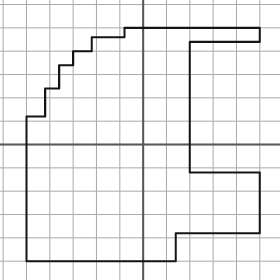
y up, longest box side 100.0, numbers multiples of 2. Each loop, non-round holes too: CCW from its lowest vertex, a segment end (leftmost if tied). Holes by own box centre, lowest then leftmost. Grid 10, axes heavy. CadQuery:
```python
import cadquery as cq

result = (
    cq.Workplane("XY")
    .moveTo(-50.0, -50.0)
    .lineTo(14.0, -50.0)
    .lineTo(14.0, -38.0)
    .lineTo(50.0, -38.0)
    .lineTo(50.0, -12.0)
    .lineTo(20.0, -12.0)
    .lineTo(20.0, 44.0)
    .lineTo(50.0, 44.0)
    .lineTo(50.0, 50.0)
    .lineTo(-8.0, 50.0)
    .lineTo(-8.0, 46.0)
    .lineTo(-22.0, 46.0)
    .lineTo(-22.0, 40.0)
    .lineTo(-30.0, 40.0)
    .lineTo(-30.0, 34.0)
    .lineTo(-36.0, 34.0)
    .lineTo(-36.0, 24.0)
    .lineTo(-42.0, 24.0)
    .lineTo(-42.0, 12.0)
    .lineTo(-50.0, 12.0)
    .close()
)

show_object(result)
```